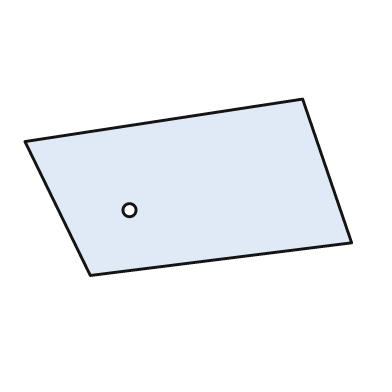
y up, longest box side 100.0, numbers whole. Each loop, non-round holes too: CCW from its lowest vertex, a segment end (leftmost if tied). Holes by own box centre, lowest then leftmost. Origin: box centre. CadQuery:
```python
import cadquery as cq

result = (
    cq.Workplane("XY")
    .moveTo(-30.0, -27.0)
    .lineTo(50.0, -17.0)
    .lineTo(35.0, 27.0)
    .lineTo(-50.0, 14.0)
    .close()
    .moveTo(-18.0, -7.0)
    .circle(2.0)
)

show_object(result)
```